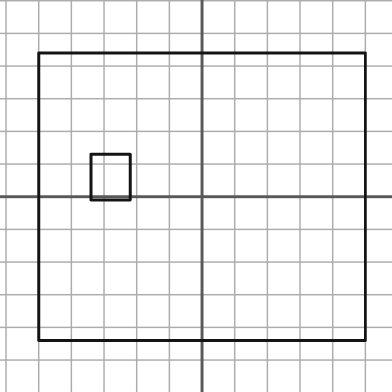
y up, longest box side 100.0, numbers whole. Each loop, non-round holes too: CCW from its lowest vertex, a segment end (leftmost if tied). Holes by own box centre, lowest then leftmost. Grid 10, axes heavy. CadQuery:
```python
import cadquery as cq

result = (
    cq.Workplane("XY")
    .moveTo(-50.0, -44.0)
    .lineTo(50.0, -44.0)
    .lineTo(50.0, 44.0)
    .lineTo(-50.0, 44.0)
    .close()
    .moveTo(-34.0, -1.0)
    .lineTo(-22.0, -1.0)
    .lineTo(-22.0, 13.0)
    .lineTo(-34.0, 13.0)
    .close()
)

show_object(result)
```